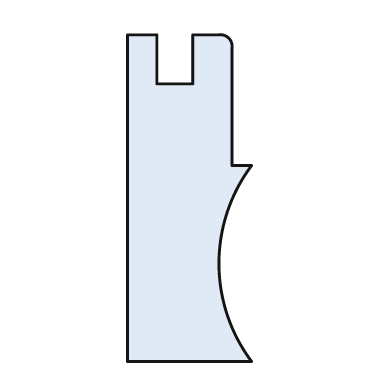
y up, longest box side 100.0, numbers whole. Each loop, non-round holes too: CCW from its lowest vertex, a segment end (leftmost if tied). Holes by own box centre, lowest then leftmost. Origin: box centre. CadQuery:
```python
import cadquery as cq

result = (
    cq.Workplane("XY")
    .moveTo(-19.0, -50.0)
    .lineTo(19.0, -50.0)
    .threePointArc((9.0, -20.0), (19.0, 10.0))
    .lineTo(13.0, 10.0)
    .lineTo(13.0, 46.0)
    .threePointArc((12.0, 49.0), (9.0, 50.0))
    .lineTo(1.0, 50.0)
    .lineTo(1.0, 35.0)
    .lineTo(-10.0, 35.0)
    .lineTo(-10.0, 50.0)
    .lineTo(-19.0, 50.0)
    .close()
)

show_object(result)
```